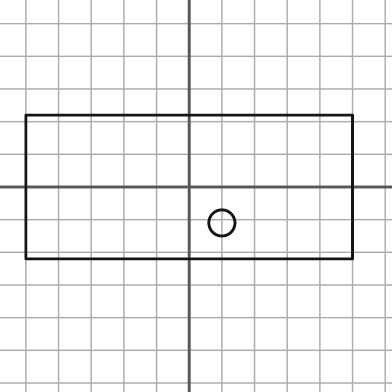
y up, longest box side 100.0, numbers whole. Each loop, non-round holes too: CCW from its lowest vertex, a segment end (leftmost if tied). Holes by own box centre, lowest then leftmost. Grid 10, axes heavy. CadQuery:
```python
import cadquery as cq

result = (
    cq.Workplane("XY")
    .moveTo(-50.0, -22.0)
    .lineTo(50.0, -22.0)
    .lineTo(50.0, 22.0)
    .lineTo(-50.0, 22.0)
    .close()
    .moveTo(10.0, -11.0)
    .circle(4.0)
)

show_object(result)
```